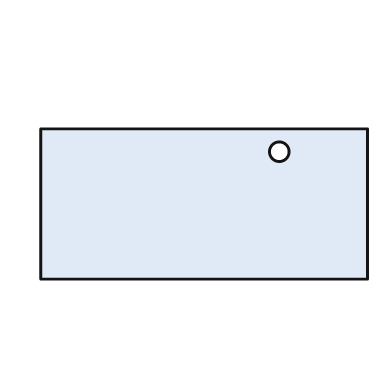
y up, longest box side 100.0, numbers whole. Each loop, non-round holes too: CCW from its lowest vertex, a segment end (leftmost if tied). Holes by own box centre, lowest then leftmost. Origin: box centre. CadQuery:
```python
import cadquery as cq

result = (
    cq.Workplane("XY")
    .moveTo(-50.0, -23.0)
    .lineTo(50.0, -23.0)
    .lineTo(50.0, 23.0)
    .lineTo(-50.0, 23.0)
    .close()
    .moveTo(23.0, 16.0)
    .circle(3.0)
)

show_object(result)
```